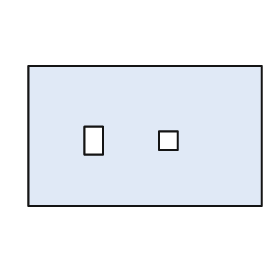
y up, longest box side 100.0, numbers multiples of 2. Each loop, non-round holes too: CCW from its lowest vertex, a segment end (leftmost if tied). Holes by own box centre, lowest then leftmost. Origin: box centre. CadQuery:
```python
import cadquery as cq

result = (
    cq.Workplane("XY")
    .moveTo(-50.0, -30.0)
    .lineTo(50.0, -30.0)
    .lineTo(50.0, 30.0)
    .lineTo(-50.0, 30.0)
    .close()
    .moveTo(-26.0, -8.0)
    .lineTo(-18.0, -8.0)
    .lineTo(-18.0, 4.0)
    .lineTo(-26.0, 4.0)
    .close()
    .moveTo(6.0, -6.0)
    .lineTo(14.0, -6.0)
    .lineTo(14.0, 2.0)
    .lineTo(6.0, 2.0)
    .close()
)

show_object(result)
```